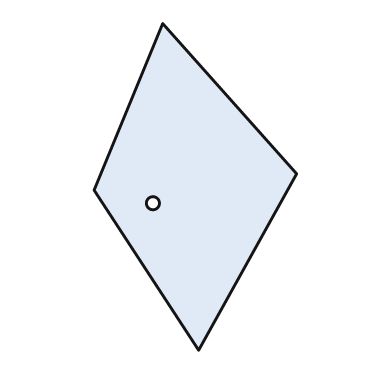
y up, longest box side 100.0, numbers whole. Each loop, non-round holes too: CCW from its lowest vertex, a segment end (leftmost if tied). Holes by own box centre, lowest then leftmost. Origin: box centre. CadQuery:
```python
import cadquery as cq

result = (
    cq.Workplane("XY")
    .moveTo(1.0, -50.0)
    .lineTo(31.0, 4.0)
    .lineTo(-10.0, 50.0)
    .lineTo(-31.0, -1.0)
    .close()
    .moveTo(-13.0, -5.0)
    .circle(2.0)
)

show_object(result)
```